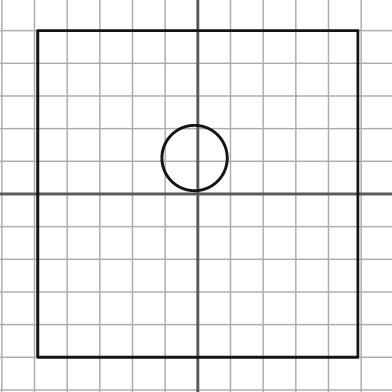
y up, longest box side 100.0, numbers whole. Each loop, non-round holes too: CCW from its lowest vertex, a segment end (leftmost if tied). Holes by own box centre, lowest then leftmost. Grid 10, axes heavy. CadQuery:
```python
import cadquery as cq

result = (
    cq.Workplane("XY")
    .moveTo(-49.0, -50.0)
    .lineTo(49.0, -50.0)
    .lineTo(49.0, 50.0)
    .lineTo(-49.0, 50.0)
    .close()
    .moveTo(-1.0, 11.0)
    .circle(10.0)
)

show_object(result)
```